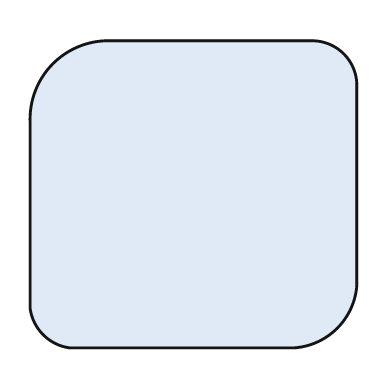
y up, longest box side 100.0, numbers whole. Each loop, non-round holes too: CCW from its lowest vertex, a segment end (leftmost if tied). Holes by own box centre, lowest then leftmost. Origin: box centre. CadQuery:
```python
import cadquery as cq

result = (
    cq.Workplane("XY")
    .moveTo(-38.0, -47.0)
    .lineTo(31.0, -47.0)
    .threePointArc((44.0, -41.0), (50.0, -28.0))
    .lineTo(50.0, 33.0)
    .threePointArc((46.0, 43.0), (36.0, 47.0))
    .lineTo(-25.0, 47.0)
    .threePointArc((-43.0, 40.0), (-50.0, 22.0))
    .lineTo(-50.0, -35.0)
    .threePointArc((-46.0, -43.0), (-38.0, -47.0))
    .close()
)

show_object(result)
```